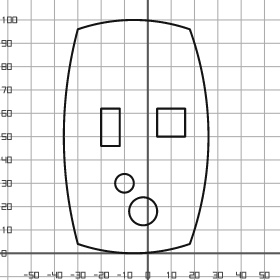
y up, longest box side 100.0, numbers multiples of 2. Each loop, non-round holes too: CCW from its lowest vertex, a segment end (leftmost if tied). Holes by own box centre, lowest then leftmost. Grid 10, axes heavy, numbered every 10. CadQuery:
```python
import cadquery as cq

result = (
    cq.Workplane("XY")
    .moveTo(-30.0, 4.0)
    .threePointArc((-6.0, 0.0), (18.0, 4.0))
    .threePointArc((26.0, 50.0), (18.0, 96.0))
    .threePointArc((-6.0, 100.0), (-30.0, 96.0))
    .threePointArc((-36.0, 50.0), (-30.0, 4.0))
    .close()
    .moveTo(-2.0, 18.0)
    .circle(6.0)
    .moveTo(-10.0, 30.0)
    .circle(4.0)
    .moveTo(-20.0, 46.0)
    .lineTo(-12.0, 46.0)
    .lineTo(-12.0, 62.0)
    .lineTo(-20.0, 62.0)
    .close()
    .moveTo(4.0, 50.0)
    .lineTo(16.0, 50.0)
    .lineTo(16.0, 62.0)
    .lineTo(4.0, 62.0)
    .close()
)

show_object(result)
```